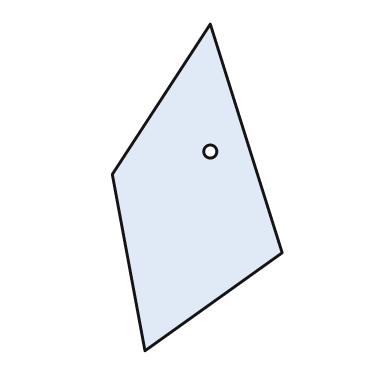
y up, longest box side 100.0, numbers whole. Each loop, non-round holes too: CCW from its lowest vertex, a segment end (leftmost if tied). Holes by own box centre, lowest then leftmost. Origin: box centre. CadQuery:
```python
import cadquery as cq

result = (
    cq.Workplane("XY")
    .moveTo(-16.0, -50.0)
    .lineTo(26.0, -20.0)
    .lineTo(4.0, 50.0)
    .lineTo(-26.0, 4.0)
    .close()
    .moveTo(4.0, 11.0)
    .circle(2.0)
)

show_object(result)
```